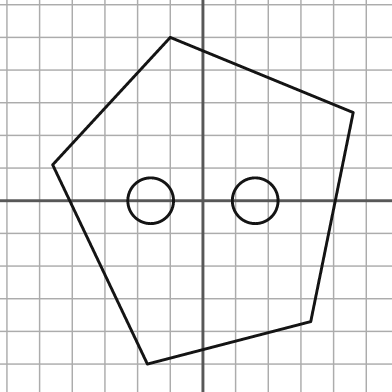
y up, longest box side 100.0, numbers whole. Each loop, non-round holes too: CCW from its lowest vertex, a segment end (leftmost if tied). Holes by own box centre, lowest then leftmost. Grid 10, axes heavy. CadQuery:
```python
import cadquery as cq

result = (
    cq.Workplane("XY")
    .moveTo(-17.0, -50.0)
    .lineTo(33.0, -37.0)
    .lineTo(46.0, 27.0)
    .lineTo(-10.0, 50.0)
    .lineTo(-46.0, 11.0)
    .close()
    .moveTo(-16.0, 0.0)
    .circle(7.0)
    .moveTo(16.0, 0.0)
    .circle(7.0)
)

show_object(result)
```